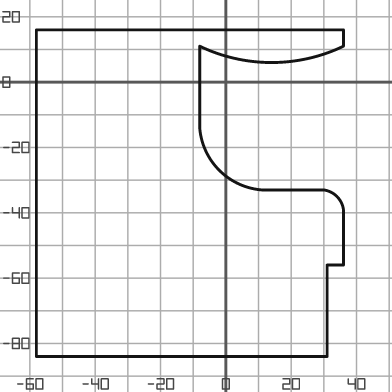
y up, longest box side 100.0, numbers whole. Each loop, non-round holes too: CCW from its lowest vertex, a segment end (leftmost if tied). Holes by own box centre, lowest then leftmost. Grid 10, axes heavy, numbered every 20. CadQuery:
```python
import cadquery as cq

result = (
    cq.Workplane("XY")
    .moveTo(-58.0, -84.0)
    .lineTo(31.0, -84.0)
    .lineTo(31.0, -56.0)
    .lineTo(36.0, -56.0)
    .lineTo(36.0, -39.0)
    .threePointArc((34.0, -35.0), (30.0, -33.0))
    .lineTo(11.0, -33.0)
    .threePointArc((-2.0, -27.0), (-8.0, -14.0))
    .lineTo(-8.0, 11.0)
    .threePointArc((14.0, 6.0), (36.0, 11.0))
    .lineTo(36.0, 16.0)
    .lineTo(-58.0, 16.0)
    .close()
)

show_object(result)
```